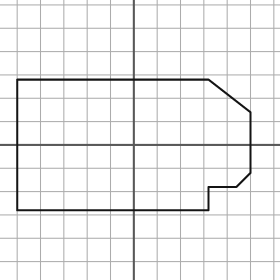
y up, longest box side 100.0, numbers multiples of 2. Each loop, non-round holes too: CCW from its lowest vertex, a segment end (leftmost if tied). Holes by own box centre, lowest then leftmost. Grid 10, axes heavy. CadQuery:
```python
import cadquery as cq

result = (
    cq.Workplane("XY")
    .moveTo(-50.0, -28.0)
    .lineTo(32.0, -28.0)
    .lineTo(32.0, -18.0)
    .lineTo(44.0, -18.0)
    .lineTo(50.0, -12.0)
    .lineTo(50.0, 14.0)
    .lineTo(32.0, 28.0)
    .lineTo(-50.0, 28.0)
    .close()
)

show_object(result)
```